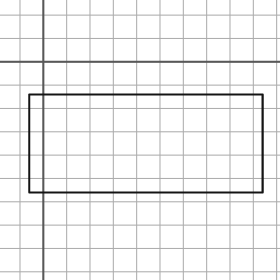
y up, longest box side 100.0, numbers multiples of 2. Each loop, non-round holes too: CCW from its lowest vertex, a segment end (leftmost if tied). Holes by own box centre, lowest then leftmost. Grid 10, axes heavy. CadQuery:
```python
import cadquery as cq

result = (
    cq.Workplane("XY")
    .moveTo(-6.0, -56.0)
    .lineTo(94.0, -56.0)
    .lineTo(94.0, -14.0)
    .lineTo(-6.0, -14.0)
    .close()
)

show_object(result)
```